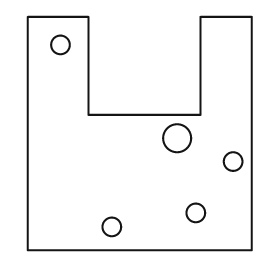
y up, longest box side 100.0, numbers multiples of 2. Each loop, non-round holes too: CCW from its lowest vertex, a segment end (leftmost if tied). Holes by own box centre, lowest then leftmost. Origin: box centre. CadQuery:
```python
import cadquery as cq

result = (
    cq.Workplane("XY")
    .moveTo(-48.0, -50.0)
    .lineTo(48.0, -50.0)
    .lineTo(48.0, 50.0)
    .lineTo(26.0, 50.0)
    .lineTo(26.0, 8.0)
    .lineTo(-22.0, 8.0)
    .lineTo(-22.0, 50.0)
    .lineTo(-48.0, 50.0)
    .close()
    .moveTo(-12.0, -40.0)
    .circle(4.0)
    .moveTo(24.0, -34.0)
    .circle(4.0)
    .moveTo(40.0, -12.0)
    .circle(4.0)
    .moveTo(16.0, -2.0)
    .circle(6.0)
    .moveTo(-34.0, 38.0)
    .circle(4.0)
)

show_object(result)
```